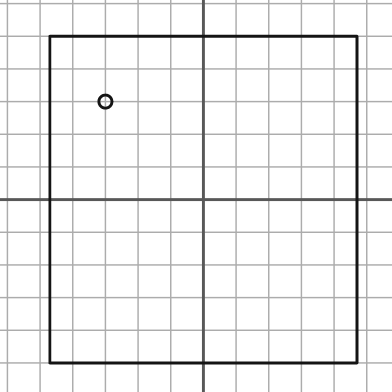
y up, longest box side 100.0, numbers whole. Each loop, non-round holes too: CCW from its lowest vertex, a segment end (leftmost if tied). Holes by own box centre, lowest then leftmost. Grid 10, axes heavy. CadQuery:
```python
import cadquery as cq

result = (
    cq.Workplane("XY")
    .moveTo(-47.0, -50.0)
    .lineTo(47.0, -50.0)
    .lineTo(47.0, 50.0)
    .lineTo(-47.0, 50.0)
    .close()
    .moveTo(-30.0, 30.0)
    .circle(2.0)
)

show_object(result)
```